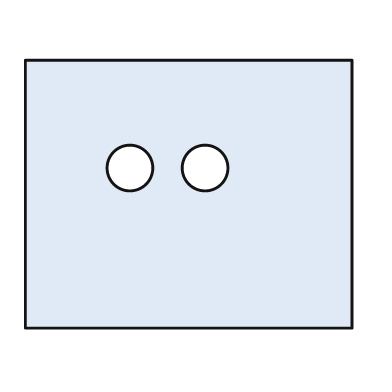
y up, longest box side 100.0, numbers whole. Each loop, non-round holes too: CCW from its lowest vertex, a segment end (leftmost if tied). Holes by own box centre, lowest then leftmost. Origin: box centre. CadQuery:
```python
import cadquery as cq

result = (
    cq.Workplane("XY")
    .moveTo(-50.0, -41.0)
    .lineTo(50.0, -41.0)
    .lineTo(50.0, 41.0)
    .lineTo(-50.0, 41.0)
    .close()
    .moveTo(-18.0, 8.0)
    .circle(7.0)
    .moveTo(5.0, 8.0)
    .circle(7.0)
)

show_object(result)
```